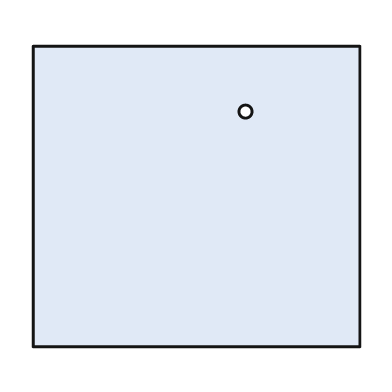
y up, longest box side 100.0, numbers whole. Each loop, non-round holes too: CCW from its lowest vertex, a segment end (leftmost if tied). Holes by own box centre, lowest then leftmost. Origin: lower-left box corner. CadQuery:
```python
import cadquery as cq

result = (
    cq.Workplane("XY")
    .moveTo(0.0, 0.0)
    .lineTo(100.0, 0.0)
    .lineTo(100.0, 92.0)
    .lineTo(0.0, 92.0)
    .close()
    .moveTo(65.0, 72.0)
    .circle(2.0)
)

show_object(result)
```